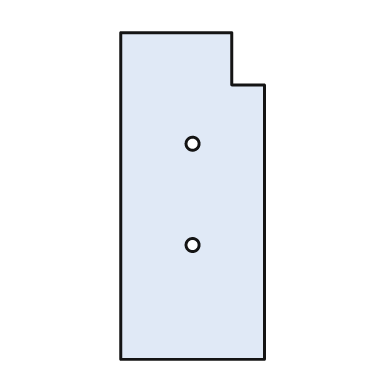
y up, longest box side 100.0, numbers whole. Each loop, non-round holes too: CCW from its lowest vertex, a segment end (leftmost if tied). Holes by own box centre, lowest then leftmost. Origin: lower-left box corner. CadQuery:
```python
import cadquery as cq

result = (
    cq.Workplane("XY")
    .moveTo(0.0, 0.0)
    .lineTo(44.0, 0.0)
    .lineTo(44.0, 84.0)
    .lineTo(34.0, 84.0)
    .lineTo(34.0, 100.0)
    .lineTo(0.0, 100.0)
    .close()
    .moveTo(22.0, 35.0)
    .circle(2.0)
    .moveTo(22.0, 66.0)
    .circle(2.0)
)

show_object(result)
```